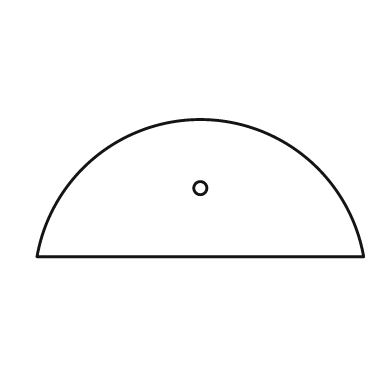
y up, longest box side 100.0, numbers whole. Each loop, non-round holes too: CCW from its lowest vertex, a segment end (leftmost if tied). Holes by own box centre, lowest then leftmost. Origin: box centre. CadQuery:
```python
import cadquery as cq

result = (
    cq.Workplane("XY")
    .moveTo(-50.0, -21.0)
    .lineTo(50.0, -21.0)
    .threePointArc((0.0, 21.0), (-50.0, -21.0))
    .close()
    .moveTo(0.0, 0.0)
    .circle(2.0)
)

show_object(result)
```